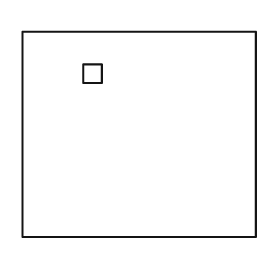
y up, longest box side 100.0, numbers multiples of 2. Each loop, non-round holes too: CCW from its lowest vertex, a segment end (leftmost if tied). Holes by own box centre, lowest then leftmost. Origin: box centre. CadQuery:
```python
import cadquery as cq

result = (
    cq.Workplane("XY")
    .moveTo(-50.0, -44.0)
    .lineTo(50.0, -44.0)
    .lineTo(50.0, 44.0)
    .lineTo(-50.0, 44.0)
    .close()
    .moveTo(-24.0, 22.0)
    .lineTo(-16.0, 22.0)
    .lineTo(-16.0, 30.0)
    .lineTo(-24.0, 30.0)
    .close()
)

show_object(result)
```